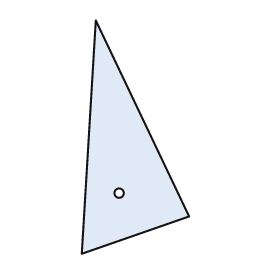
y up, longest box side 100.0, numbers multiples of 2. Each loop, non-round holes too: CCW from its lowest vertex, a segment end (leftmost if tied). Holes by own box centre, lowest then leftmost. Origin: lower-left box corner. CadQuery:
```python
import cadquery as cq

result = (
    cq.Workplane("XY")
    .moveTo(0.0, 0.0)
    .lineTo(46.0, 16.0)
    .lineTo(6.0, 100.0)
    .close()
    .moveTo(16.0, 26.0)
    .circle(2.0)
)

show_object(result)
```